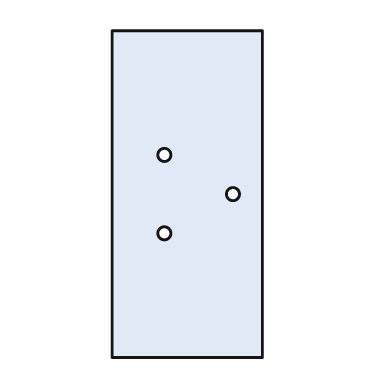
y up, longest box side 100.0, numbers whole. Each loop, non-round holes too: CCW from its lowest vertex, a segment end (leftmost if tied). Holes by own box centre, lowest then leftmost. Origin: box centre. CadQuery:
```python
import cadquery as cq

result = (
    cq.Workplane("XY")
    .moveTo(-23.0, -50.0)
    .lineTo(23.0, -50.0)
    .lineTo(23.0, 50.0)
    .lineTo(-23.0, 50.0)
    .close()
    .moveTo(-7.0, -12.0)
    .circle(2.0)
    .moveTo(14.0, 0.0)
    .circle(2.0)
    .moveTo(-7.0, 12.0)
    .circle(2.0)
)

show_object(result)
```